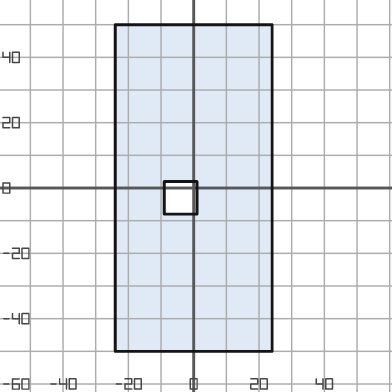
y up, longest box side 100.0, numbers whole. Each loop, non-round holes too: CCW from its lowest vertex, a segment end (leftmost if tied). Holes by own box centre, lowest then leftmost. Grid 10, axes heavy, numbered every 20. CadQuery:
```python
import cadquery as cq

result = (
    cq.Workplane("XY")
    .moveTo(-24.0, -50.0)
    .lineTo(24.0, -50.0)
    .lineTo(24.0, 50.0)
    .lineTo(-24.0, 50.0)
    .close()
    .moveTo(-9.0, -8.0)
    .lineTo(1.0, -8.0)
    .lineTo(1.0, 2.0)
    .lineTo(-9.0, 2.0)
    .close()
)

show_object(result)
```